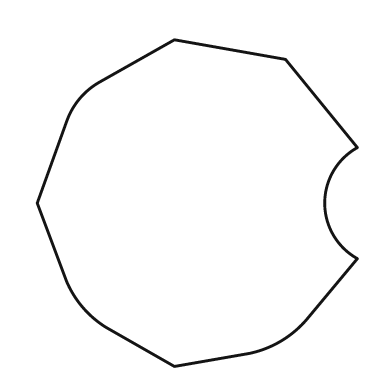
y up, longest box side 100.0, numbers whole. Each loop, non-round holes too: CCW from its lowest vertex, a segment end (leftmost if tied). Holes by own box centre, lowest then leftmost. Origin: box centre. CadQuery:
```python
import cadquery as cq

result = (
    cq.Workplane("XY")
    .moveTo(-7.0, -50.0)
    .lineTo(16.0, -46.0)
    .threePointArc((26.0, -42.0), (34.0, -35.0))
    .lineTo(49.0, -17.0)
    .threePointArc((39.0, 0.0), (49.0, 17.0))
    .lineTo(27.0, 44.0)
    .lineTo(-7.0, 50.0)
    .lineTo(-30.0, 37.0)
    .threePointArc((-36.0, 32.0), (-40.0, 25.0))
    .lineTo(-49.0, 0.0)
    .lineTo(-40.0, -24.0)
    .threePointArc((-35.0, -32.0), (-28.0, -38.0))
    .close()
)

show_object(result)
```